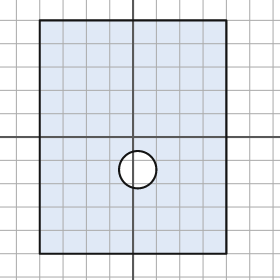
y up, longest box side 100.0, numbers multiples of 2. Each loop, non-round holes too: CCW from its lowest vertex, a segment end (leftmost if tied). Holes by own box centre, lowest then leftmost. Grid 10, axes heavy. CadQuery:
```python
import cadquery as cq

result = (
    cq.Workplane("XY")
    .moveTo(-40.0, -50.0)
    .lineTo(40.0, -50.0)
    .lineTo(40.0, 50.0)
    .lineTo(-40.0, 50.0)
    .close()
    .moveTo(2.0, -14.0)
    .circle(8.0)
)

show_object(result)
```